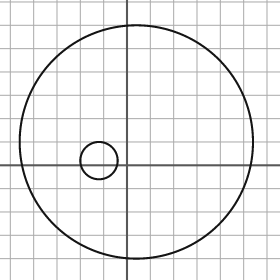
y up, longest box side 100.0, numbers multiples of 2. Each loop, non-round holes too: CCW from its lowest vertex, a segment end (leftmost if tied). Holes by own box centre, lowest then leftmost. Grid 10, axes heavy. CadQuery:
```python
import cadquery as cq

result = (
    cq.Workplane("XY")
    .moveTo(4.0, 10.0)
    .circle(50.0)
    .moveTo(-12.0, 2.0)
    .circle(8.0)
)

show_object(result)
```